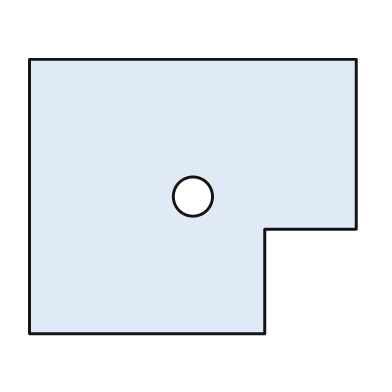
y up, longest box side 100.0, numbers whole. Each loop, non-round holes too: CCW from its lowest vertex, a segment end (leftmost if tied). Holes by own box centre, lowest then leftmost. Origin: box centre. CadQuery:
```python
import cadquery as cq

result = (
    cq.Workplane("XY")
    .moveTo(-50.0, -42.0)
    .lineTo(22.0, -42.0)
    .lineTo(22.0, -10.0)
    .lineTo(50.0, -10.0)
    .lineTo(50.0, 42.0)
    .lineTo(-50.0, 42.0)
    .close()
    .moveTo(0.0, 0.0)
    .circle(6.0)
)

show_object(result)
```